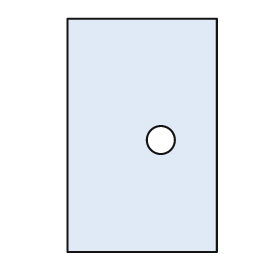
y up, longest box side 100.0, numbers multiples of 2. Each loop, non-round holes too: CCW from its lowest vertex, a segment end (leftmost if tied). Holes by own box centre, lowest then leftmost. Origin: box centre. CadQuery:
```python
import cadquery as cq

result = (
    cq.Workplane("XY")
    .moveTo(-32.0, -50.0)
    .lineTo(32.0, -50.0)
    .lineTo(32.0, 50.0)
    .lineTo(-32.0, 50.0)
    .close()
    .moveTo(8.0, -2.0)
    .circle(6.0)
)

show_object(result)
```